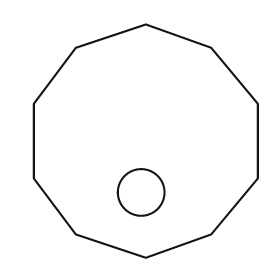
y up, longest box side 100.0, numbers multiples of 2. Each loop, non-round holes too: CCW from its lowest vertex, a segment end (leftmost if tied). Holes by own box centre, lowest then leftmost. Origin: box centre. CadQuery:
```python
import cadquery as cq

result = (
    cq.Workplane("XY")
    .moveTo(0.0, -50.0)
    .lineTo(28.0, -40.0)
    .lineTo(48.0, -16.0)
    .lineTo(48.0, 16.0)
    .lineTo(28.0, 40.0)
    .lineTo(0.0, 50.0)
    .lineTo(-30.0, 40.0)
    .lineTo(-48.0, 16.0)
    .lineTo(-48.0, -16.0)
    .lineTo(-30.0, -40.0)
    .close()
    .moveTo(-2.0, -22.0)
    .circle(10.0)
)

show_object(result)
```